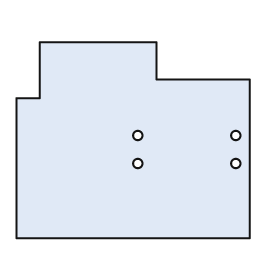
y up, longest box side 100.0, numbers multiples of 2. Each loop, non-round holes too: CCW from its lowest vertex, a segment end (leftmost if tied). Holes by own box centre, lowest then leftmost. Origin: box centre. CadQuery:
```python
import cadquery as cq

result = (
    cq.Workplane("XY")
    .moveTo(-50.0, -42.0)
    .lineTo(50.0, -42.0)
    .lineTo(50.0, 26.0)
    .lineTo(10.0, 26.0)
    .lineTo(10.0, 42.0)
    .lineTo(-40.0, 42.0)
    .lineTo(-40.0, 18.0)
    .lineTo(-50.0, 18.0)
    .close()
    .moveTo(2.0, -10.0)
    .circle(2.0)
    .moveTo(44.0, -10.0)
    .circle(2.0)
    .moveTo(2.0, 2.0)
    .circle(2.0)
    .moveTo(44.0, 2.0)
    .circle(2.0)
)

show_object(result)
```